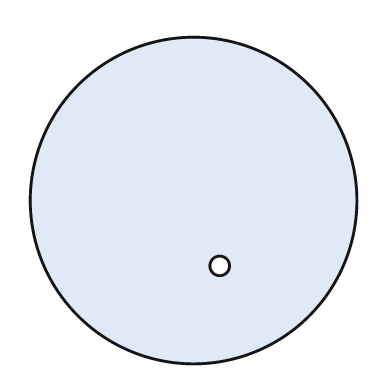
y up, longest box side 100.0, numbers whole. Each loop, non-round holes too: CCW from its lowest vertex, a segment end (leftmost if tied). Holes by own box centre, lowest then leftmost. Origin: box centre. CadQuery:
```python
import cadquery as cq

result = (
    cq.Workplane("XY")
    .moveTo(0.0, 0.0)
    .circle(50.0)
    .moveTo(8.0, -20.0)
    .circle(3.0)
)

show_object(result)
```